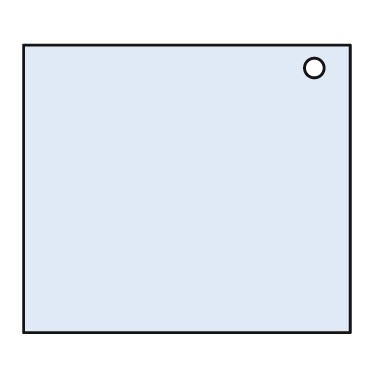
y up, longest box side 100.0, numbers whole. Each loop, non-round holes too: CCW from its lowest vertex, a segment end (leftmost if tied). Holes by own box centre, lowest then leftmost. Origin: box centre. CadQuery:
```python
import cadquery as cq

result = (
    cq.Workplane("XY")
    .moveTo(-50.0, -44.0)
    .lineTo(50.0, -44.0)
    .lineTo(50.0, 44.0)
    .lineTo(-50.0, 44.0)
    .close()
    .moveTo(39.0, 37.0)
    .circle(3.0)
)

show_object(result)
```